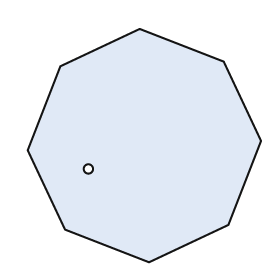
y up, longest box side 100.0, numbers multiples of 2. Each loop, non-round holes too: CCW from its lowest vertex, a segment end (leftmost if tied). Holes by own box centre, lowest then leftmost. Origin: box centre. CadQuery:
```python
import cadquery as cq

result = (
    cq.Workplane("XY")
    .moveTo(2.0, -50.0)
    .lineTo(36.0, -34.0)
    .lineTo(50.0, 2.0)
    .lineTo(34.0, 36.0)
    .lineTo(-2.0, 50.0)
    .lineTo(-36.0, 34.0)
    .lineTo(-50.0, -2.0)
    .lineTo(-34.0, -36.0)
    .close()
    .moveTo(-24.0, -10.0)
    .circle(2.0)
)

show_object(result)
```